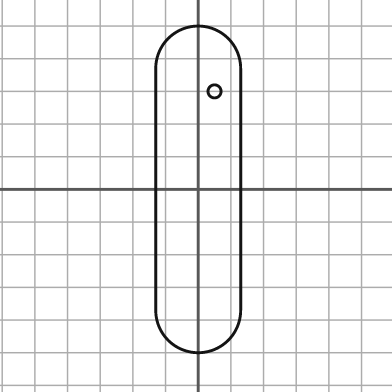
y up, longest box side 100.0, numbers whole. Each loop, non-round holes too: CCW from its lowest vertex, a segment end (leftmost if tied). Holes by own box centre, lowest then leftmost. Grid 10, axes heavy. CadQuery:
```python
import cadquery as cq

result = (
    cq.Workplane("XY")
    .moveTo(-13.0, -37.0)
    .threePointArc((0.0, -50.0), (13.0, -37.0))
    .lineTo(13.0, 37.0)
    .threePointArc((0.0, 50.0), (-13.0, 37.0))
    .close()
    .moveTo(5.0, 30.0)
    .circle(2.0)
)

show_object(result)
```